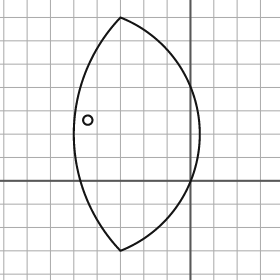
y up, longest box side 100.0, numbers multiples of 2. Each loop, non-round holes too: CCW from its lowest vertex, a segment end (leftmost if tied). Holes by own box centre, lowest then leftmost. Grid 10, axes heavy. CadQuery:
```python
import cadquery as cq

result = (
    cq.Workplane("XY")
    .moveTo(-30.0, -30.0)
    .threePointArc((4.0, 20.0), (-30.0, 70.0))
    .threePointArc((-50.0, 20.0), (-30.0, -30.0))
    .close()
    .moveTo(-44.0, 26.0)
    .circle(2.0)
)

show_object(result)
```